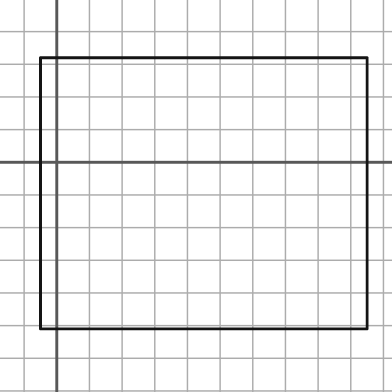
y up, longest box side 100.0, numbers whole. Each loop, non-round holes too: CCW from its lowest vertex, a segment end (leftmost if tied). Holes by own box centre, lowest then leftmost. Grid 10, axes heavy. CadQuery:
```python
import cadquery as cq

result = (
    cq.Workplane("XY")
    .moveTo(-5.0, -51.0)
    .lineTo(95.0, -51.0)
    .lineTo(95.0, 32.0)
    .lineTo(-5.0, 32.0)
    .close()
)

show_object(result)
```